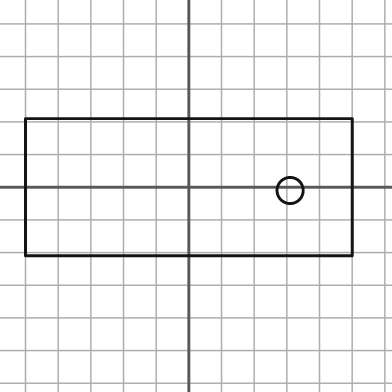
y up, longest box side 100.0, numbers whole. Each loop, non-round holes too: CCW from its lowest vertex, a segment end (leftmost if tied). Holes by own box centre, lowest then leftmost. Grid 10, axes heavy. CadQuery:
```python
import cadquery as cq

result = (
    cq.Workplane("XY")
    .moveTo(-50.0, -21.0)
    .lineTo(50.0, -21.0)
    .lineTo(50.0, 21.0)
    .lineTo(-50.0, 21.0)
    .close()
    .moveTo(31.0, -1.0)
    .circle(4.0)
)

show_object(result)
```